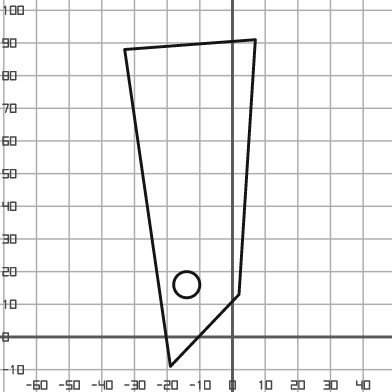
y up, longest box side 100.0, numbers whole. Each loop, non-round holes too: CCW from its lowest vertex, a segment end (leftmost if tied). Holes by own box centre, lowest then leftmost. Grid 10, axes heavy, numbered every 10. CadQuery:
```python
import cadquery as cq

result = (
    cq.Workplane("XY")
    .moveTo(-19.0, -9.0)
    .lineTo(2.0, 13.0)
    .lineTo(7.0, 91.0)
    .lineTo(-33.0, 88.0)
    .close()
    .moveTo(-14.0, 16.0)
    .circle(4.0)
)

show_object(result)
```